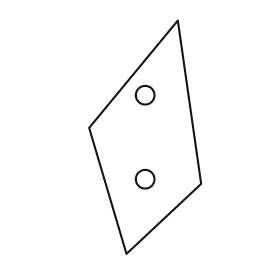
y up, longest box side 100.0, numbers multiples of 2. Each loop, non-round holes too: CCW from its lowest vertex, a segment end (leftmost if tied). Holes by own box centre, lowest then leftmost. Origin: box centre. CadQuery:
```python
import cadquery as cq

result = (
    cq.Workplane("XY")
    .moveTo(-8.0, -50.0)
    .lineTo(24.0, -20.0)
    .lineTo(14.0, 50.0)
    .lineTo(-24.0, 4.0)
    .close()
    .moveTo(0.0, -18.0)
    .circle(4.0)
    .moveTo(0.0, 18.0)
    .circle(4.0)
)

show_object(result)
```